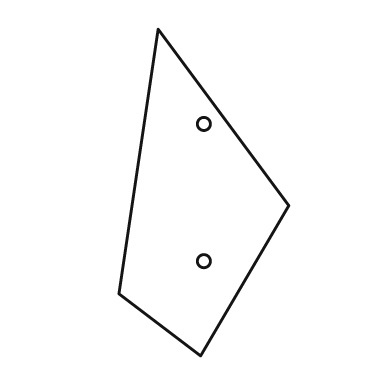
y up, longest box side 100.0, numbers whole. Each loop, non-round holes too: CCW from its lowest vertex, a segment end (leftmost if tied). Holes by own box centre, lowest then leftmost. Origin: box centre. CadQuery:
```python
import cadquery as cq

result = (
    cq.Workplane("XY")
    .moveTo(-1.0, -50.0)
    .lineTo(26.0, -4.0)
    .lineTo(-14.0, 50.0)
    .lineTo(-26.0, -31.0)
    .close()
    .moveTo(0.0, -21.0)
    .circle(2.0)
    .moveTo(0.0, 21.0)
    .circle(2.0)
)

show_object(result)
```